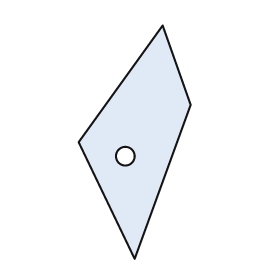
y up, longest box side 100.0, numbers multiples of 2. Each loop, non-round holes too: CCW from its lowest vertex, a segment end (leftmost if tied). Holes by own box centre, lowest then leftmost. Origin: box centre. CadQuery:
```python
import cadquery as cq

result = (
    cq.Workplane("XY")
    .moveTo(0.0, -50.0)
    .lineTo(24.0, 16.0)
    .lineTo(12.0, 50.0)
    .lineTo(-24.0, 0.0)
    .close()
    .moveTo(-4.0, -6.0)
    .circle(4.0)
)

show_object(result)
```